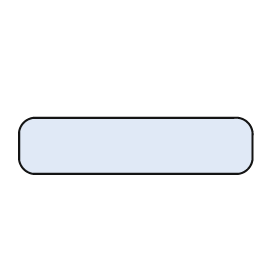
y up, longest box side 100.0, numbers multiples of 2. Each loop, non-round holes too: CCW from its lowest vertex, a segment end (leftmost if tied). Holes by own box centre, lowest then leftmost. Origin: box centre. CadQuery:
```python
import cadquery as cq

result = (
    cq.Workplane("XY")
    .moveTo(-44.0, -12.0)
    .lineTo(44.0, -12.0)
    .threePointArc((48.0, -10.0), (50.0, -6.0))
    .lineTo(50.0, 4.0)
    .threePointArc((48.0, 10.0), (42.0, 12.0))
    .lineTo(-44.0, 12.0)
    .threePointArc((-48.0, 10.0), (-50.0, 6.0))
    .lineTo(-50.0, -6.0)
    .threePointArc((-48.0, -10.0), (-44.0, -12.0))
    .close()
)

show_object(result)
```